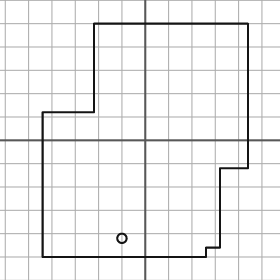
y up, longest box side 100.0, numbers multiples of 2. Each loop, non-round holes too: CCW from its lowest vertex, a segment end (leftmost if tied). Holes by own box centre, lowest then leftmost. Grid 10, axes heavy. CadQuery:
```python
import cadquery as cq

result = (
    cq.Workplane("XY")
    .moveTo(-44.0, -50.0)
    .lineTo(26.0, -50.0)
    .lineTo(26.0, -46.0)
    .lineTo(32.0, -46.0)
    .lineTo(32.0, -12.0)
    .lineTo(44.0, -12.0)
    .lineTo(44.0, 50.0)
    .lineTo(-22.0, 50.0)
    .lineTo(-22.0, 12.0)
    .lineTo(-44.0, 12.0)
    .close()
    .moveTo(-10.0, -42.0)
    .circle(2.0)
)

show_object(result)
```